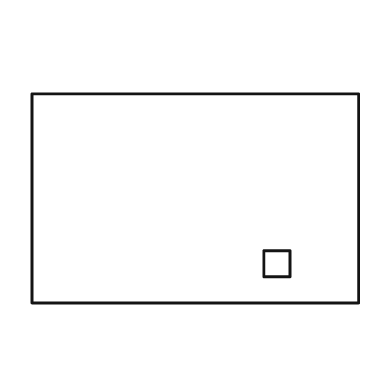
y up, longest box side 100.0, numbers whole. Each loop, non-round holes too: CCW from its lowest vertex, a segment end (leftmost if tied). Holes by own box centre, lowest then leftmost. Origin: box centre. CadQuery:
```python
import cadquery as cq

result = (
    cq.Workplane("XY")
    .moveTo(-50.0, -32.0)
    .lineTo(50.0, -32.0)
    .lineTo(50.0, 32.0)
    .lineTo(-50.0, 32.0)
    .close()
    .moveTo(21.0, -24.0)
    .lineTo(29.0, -24.0)
    .lineTo(29.0, -16.0)
    .lineTo(21.0, -16.0)
    .close()
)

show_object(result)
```